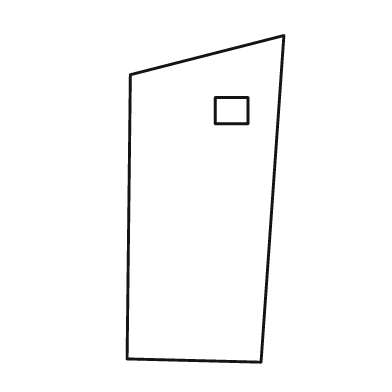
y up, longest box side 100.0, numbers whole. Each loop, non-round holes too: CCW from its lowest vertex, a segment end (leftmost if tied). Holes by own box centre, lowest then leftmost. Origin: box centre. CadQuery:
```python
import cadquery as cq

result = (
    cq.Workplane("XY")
    .moveTo(17.0, -50.0)
    .lineTo(24.0, 50.0)
    .lineTo(-23.0, 38.0)
    .lineTo(-24.0, -49.0)
    .close()
    .moveTo(3.0, 23.0)
    .lineTo(13.0, 23.0)
    .lineTo(13.0, 31.0)
    .lineTo(3.0, 31.0)
    .close()
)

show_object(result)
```